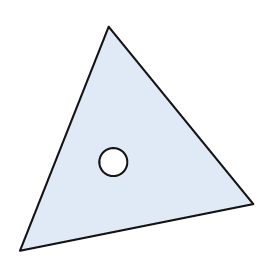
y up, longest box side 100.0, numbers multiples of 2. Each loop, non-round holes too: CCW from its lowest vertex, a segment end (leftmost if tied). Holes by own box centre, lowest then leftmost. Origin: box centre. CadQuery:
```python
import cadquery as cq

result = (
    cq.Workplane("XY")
    .moveTo(-50.0, -48.0)
    .lineTo(50.0, -28.0)
    .lineTo(-12.0, 48.0)
    .close()
    .moveTo(-10.0, -10.0)
    .circle(6.0)
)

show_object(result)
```